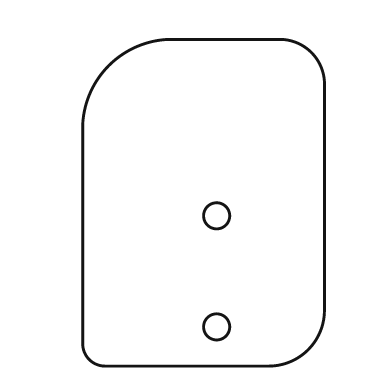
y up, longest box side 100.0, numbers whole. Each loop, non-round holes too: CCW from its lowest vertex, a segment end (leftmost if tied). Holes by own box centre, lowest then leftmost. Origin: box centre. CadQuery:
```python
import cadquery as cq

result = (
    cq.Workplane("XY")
    .moveTo(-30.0, -50.0)
    .lineTo(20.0, -50.0)
    .threePointArc((32.0, -45.0), (37.0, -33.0))
    .lineTo(37.0, 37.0)
    .threePointArc((33.0, 46.0), (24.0, 50.0))
    .lineTo(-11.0, 50.0)
    .threePointArc((-29.0, 42.0), (-37.0, 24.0))
    .lineTo(-37.0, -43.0)
    .threePointArc((-35.0, -48.0), (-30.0, -50.0))
    .close()
    .moveTo(4.0, -38.0)
    .circle(4.0)
    .moveTo(4.0, -4.0)
    .circle(4.0)
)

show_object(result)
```